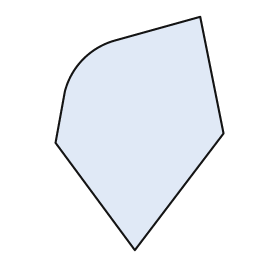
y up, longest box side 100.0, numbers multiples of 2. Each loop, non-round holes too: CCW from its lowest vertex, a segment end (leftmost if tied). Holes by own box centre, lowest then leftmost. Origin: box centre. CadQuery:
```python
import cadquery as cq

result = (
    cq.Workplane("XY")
    .moveTo(-2.0, -50.0)
    .lineTo(36.0, 0.0)
    .lineTo(26.0, 50.0)
    .lineTo(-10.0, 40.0)
    .threePointArc((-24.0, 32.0), (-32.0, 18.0))
    .lineTo(-36.0, -4.0)
    .close()
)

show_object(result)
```